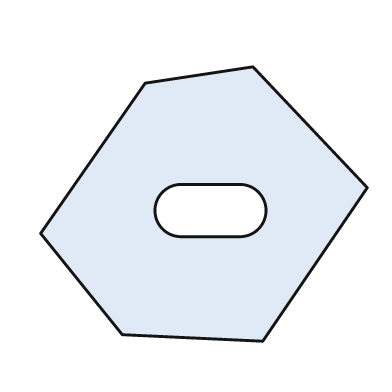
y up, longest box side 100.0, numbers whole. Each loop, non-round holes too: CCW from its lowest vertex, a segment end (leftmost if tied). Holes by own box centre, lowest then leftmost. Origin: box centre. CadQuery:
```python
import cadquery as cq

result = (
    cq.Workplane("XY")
    .moveTo(18.0, -42.0)
    .lineTo(50.0, 5.0)
    .lineTo(15.0, 42.0)
    .lineTo(-18.0, 37.0)
    .lineTo(-50.0, -9.0)
    .lineTo(-25.0, -40.0)
    .close()
    .moveTo(-7.0, -10.0)
    .lineTo(11.0, -10.0)
    .threePointArc((19.0, -2.0), (11.0, 6.0))
    .lineTo(-7.0, 6.0)
    .threePointArc((-15.0, -2.0), (-7.0, -10.0))
    .close()
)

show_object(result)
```